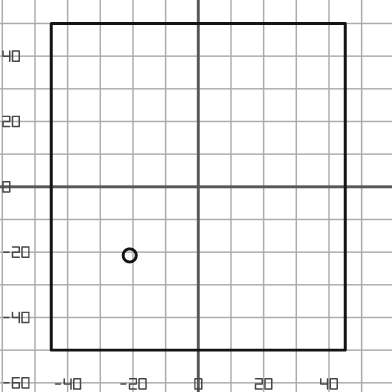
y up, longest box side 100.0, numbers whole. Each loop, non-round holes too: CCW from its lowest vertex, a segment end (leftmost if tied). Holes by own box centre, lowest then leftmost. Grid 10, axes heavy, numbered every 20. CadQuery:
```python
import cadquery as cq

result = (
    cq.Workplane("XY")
    .moveTo(-45.0, -50.0)
    .lineTo(45.0, -50.0)
    .lineTo(45.0, 50.0)
    .lineTo(-45.0, 50.0)
    .close()
    .moveTo(-21.0, -21.0)
    .circle(2.0)
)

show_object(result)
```